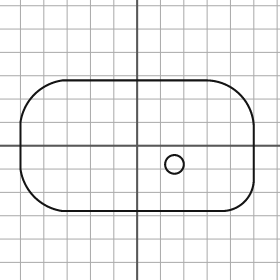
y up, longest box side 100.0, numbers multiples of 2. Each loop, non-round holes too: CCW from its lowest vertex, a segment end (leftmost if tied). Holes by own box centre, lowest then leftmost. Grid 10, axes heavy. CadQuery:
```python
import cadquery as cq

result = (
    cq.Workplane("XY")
    .moveTo(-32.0, -28.0)
    .lineTo(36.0, -28.0)
    .threePointArc((46.0, -24.0), (50.0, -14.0))
    .lineTo(50.0, 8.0)
    .threePointArc((44.0, 22.0), (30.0, 28.0))
    .lineTo(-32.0, 28.0)
    .threePointArc((-44.0, 22.0), (-50.0, 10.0))
    .lineTo(-50.0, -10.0)
    .threePointArc((-44.0, -22.0), (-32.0, -28.0))
    .close()
    .moveTo(16.0, -8.0)
    .circle(4.0)
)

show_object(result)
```